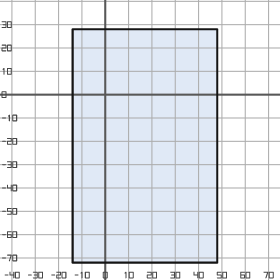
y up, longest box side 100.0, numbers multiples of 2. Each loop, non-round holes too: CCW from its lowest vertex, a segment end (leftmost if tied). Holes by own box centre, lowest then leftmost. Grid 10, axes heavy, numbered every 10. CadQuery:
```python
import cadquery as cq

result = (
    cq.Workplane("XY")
    .moveTo(-14.0, -72.0)
    .lineTo(48.0, -72.0)
    .lineTo(48.0, 28.0)
    .lineTo(-14.0, 28.0)
    .close()
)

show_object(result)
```